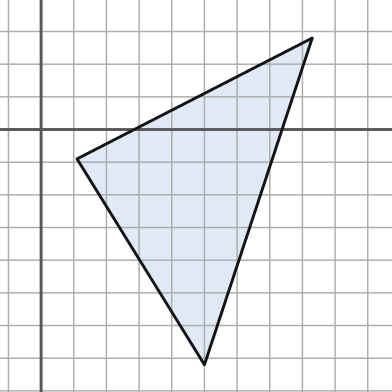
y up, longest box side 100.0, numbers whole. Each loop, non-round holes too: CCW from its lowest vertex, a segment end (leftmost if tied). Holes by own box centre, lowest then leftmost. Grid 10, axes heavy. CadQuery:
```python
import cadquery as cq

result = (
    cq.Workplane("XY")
    .moveTo(50.0, -72.0)
    .lineTo(83.0, 28.0)
    .lineTo(11.0, -9.0)
    .close()
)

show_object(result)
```